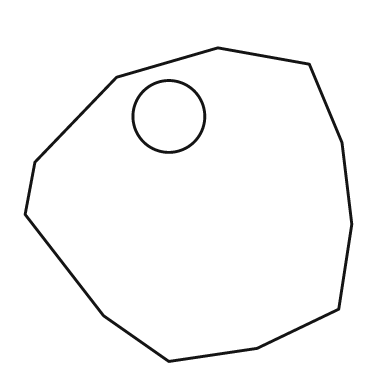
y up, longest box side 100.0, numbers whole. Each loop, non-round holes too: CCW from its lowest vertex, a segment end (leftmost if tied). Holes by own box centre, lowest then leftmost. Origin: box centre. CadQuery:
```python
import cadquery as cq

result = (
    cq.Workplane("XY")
    .moveTo(-6.0, -48.0)
    .lineTo(21.0, -44.0)
    .lineTo(46.0, -32.0)
    .lineTo(50.0, -6.0)
    .lineTo(47.0, 19.0)
    .lineTo(37.0, 43.0)
    .lineTo(9.0, 48.0)
    .lineTo(-22.0, 39.0)
    .lineTo(-47.0, 13.0)
    .lineTo(-50.0, -3.0)
    .lineTo(-26.0, -34.0)
    .close()
    .moveTo(-6.0, 27.0)
    .circle(11.0)
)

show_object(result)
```